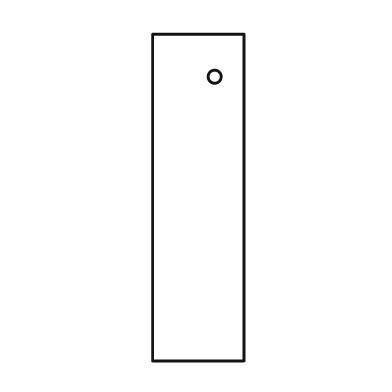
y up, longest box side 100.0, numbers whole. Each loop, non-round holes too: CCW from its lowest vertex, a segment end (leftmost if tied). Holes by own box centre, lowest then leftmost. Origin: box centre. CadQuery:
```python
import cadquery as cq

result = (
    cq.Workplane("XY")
    .moveTo(-14.0, -50.0)
    .lineTo(14.0, -50.0)
    .lineTo(14.0, 50.0)
    .lineTo(-14.0, 50.0)
    .close()
    .moveTo(5.0, 37.0)
    .circle(2.0)
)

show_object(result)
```